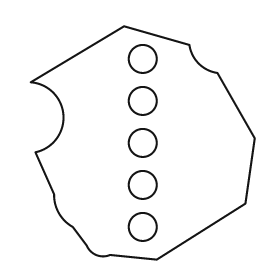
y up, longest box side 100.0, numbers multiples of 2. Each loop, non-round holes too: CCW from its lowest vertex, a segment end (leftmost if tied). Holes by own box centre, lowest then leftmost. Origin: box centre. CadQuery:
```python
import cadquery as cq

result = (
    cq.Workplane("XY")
    .moveTo(6.0, -50.0)
    .lineTo(44.0, -26.0)
    .lineTo(48.0, 2.0)
    .lineTo(32.0, 30.0)
    .threePointArc((24.0, 34.0), (20.0, 42.0))
    .lineTo(-8.0, 50.0)
    .lineTo(-48.0, 26.0)
    .threePointArc((-34.0, 12.0), (-46.0, -4.0))
    .lineTo(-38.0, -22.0)
    .threePointArc((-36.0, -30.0), (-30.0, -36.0))
    .lineTo(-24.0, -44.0)
    .threePointArc((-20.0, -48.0), (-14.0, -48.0))
    .close()
    .moveTo(0.0, -36.0)
    .circle(6.0)
    .moveTo(0.0, -18.0)
    .circle(6.0)
    .moveTo(0.0, 0.0)
    .circle(6.0)
    .moveTo(0.0, 18.0)
    .circle(6.0)
    .moveTo(0.0, 36.0)
    .circle(6.0)
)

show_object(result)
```